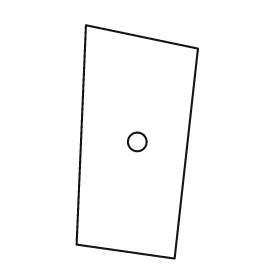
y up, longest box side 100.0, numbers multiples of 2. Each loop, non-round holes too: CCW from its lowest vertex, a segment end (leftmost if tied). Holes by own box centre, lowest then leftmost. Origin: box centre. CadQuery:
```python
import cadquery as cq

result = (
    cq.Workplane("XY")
    .moveTo(16.0, -50.0)
    .lineTo(26.0, 40.0)
    .lineTo(-22.0, 50.0)
    .lineTo(-26.0, -44.0)
    .close()
    .moveTo(0.0, 0.0)
    .circle(4.0)
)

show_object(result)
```